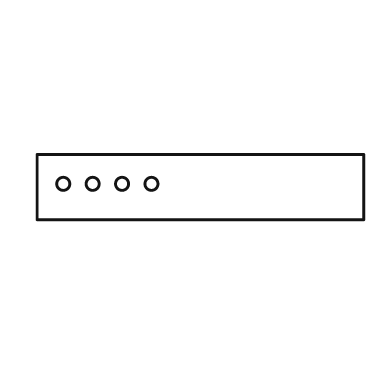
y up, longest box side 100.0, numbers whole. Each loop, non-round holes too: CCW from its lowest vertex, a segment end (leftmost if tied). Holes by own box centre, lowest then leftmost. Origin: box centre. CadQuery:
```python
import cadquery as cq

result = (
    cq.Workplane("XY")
    .moveTo(-50.0, -10.0)
    .lineTo(50.0, -10.0)
    .lineTo(50.0, 10.0)
    .lineTo(-50.0, 10.0)
    .close()
    .moveTo(-42.0, 1.0)
    .circle(2.0)
    .moveTo(-33.0, 1.0)
    .circle(2.0)
    .moveTo(-24.0, 1.0)
    .circle(2.0)
    .moveTo(-15.0, 1.0)
    .circle(2.0)
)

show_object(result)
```